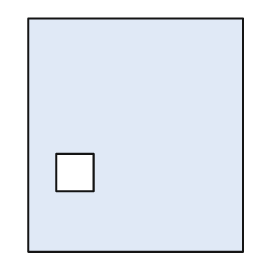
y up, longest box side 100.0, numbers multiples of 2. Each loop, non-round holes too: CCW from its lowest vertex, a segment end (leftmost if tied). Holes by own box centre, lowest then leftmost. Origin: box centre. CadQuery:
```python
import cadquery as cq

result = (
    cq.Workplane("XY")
    .moveTo(-46.0, -50.0)
    .lineTo(46.0, -50.0)
    .lineTo(46.0, 50.0)
    .lineTo(-46.0, 50.0)
    .close()
    .moveTo(-34.0, -24.0)
    .lineTo(-18.0, -24.0)
    .lineTo(-18.0, -8.0)
    .lineTo(-34.0, -8.0)
    .close()
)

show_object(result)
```